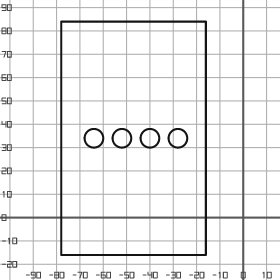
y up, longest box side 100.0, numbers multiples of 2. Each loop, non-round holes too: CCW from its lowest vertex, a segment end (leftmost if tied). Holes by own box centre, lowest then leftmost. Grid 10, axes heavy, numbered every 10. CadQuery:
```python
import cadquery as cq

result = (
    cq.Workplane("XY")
    .moveTo(-78.0, -16.0)
    .lineTo(-16.0, -16.0)
    .lineTo(-16.0, 84.0)
    .lineTo(-78.0, 84.0)
    .close()
    .moveTo(-64.0, 34.0)
    .circle(4.0)
    .moveTo(-52.0, 34.0)
    .circle(4.0)
    .moveTo(-40.0, 34.0)
    .circle(4.0)
    .moveTo(-28.0, 34.0)
    .circle(4.0)
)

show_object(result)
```